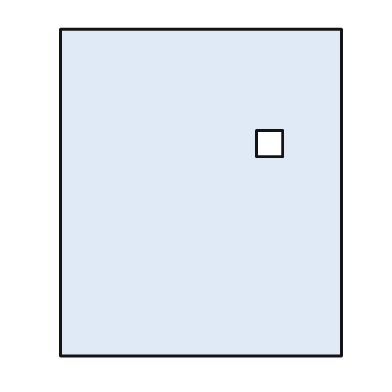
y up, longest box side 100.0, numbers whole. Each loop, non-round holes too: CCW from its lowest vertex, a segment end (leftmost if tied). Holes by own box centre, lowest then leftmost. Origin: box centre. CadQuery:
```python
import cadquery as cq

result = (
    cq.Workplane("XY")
    .moveTo(-43.0, -50.0)
    .lineTo(43.0, -50.0)
    .lineTo(43.0, 50.0)
    .lineTo(-43.0, 50.0)
    .close()
    .moveTo(17.0, 11.0)
    .lineTo(25.0, 11.0)
    .lineTo(25.0, 19.0)
    .lineTo(17.0, 19.0)
    .close()
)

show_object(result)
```